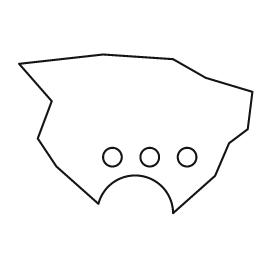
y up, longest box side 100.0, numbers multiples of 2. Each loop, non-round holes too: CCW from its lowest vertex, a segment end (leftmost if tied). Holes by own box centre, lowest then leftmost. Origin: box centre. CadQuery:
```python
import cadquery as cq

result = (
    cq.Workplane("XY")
    .moveTo(16.0, -34.0)
    .lineTo(34.0, -18.0)
    .lineTo(40.0, -4.0)
    .lineTo(48.0, 2.0)
    .lineTo(50.0, 18.0)
    .lineTo(30.0, 24.0)
    .lineTo(16.0, 32.0)
    .lineTo(-14.0, 34.0)
    .lineTo(-50.0, 30.0)
    .lineTo(-36.0, 14.0)
    .lineTo(-42.0, -2.0)
    .lineTo(-34.0, -14.0)
    .lineTo(-16.0, -30.0)
    .threePointArc((2.0, -18.0), (16.0, -34.0))
    .close()
    .moveTo(-10.0, -10.0)
    .circle(4.0)
    .moveTo(6.0, -10.0)
    .circle(4.0)
    .moveTo(22.0, -10.0)
    .circle(4.0)
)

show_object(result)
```